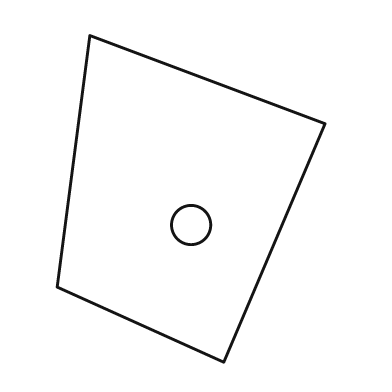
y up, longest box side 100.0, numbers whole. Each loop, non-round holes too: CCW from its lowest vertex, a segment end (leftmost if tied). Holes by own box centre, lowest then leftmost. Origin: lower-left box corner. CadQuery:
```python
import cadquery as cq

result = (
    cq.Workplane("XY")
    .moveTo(51.0, 0.0)
    .lineTo(82.0, 73.0)
    .lineTo(10.0, 100.0)
    .lineTo(0.0, 23.0)
    .close()
    .moveTo(41.0, 42.0)
    .circle(6.0)
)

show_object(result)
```